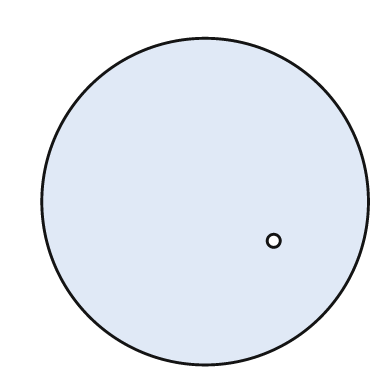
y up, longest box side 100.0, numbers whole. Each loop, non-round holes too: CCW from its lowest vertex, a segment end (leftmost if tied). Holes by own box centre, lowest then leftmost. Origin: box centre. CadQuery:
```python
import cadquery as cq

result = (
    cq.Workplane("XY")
    .moveTo(0.0, 0.0)
    .circle(50.0)
    .moveTo(21.0, -12.0)
    .circle(2.0)
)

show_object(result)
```